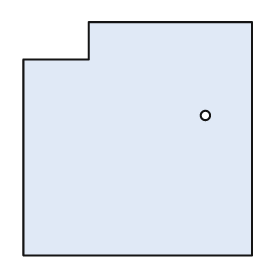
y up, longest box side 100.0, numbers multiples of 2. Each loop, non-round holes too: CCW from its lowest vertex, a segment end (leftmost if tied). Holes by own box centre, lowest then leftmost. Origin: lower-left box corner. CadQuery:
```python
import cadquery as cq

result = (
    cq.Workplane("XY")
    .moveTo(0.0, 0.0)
    .lineTo(98.0, 0.0)
    .lineTo(98.0, 100.0)
    .lineTo(28.0, 100.0)
    .lineTo(28.0, 84.0)
    .lineTo(0.0, 84.0)
    .close()
    .moveTo(78.0, 60.0)
    .circle(2.0)
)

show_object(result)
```